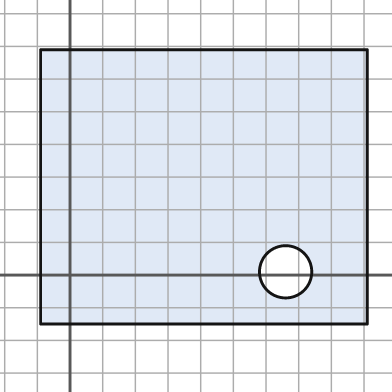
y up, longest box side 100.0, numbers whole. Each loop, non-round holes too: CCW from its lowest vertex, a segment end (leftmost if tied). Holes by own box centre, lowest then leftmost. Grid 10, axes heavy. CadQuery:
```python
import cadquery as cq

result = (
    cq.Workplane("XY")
    .moveTo(-9.0, -15.0)
    .lineTo(91.0, -15.0)
    .lineTo(91.0, 69.0)
    .lineTo(-9.0, 69.0)
    .close()
    .moveTo(66.0, 1.0)
    .circle(8.0)
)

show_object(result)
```